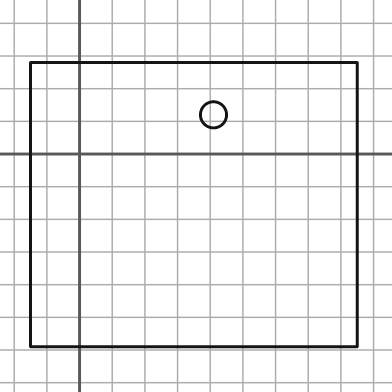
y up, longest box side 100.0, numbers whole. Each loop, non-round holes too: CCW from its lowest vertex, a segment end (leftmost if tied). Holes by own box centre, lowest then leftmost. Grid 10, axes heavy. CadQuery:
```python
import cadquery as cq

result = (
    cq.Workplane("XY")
    .moveTo(-15.0, -59.0)
    .lineTo(85.0, -59.0)
    .lineTo(85.0, 28.0)
    .lineTo(-15.0, 28.0)
    .close()
    .moveTo(41.0, 12.0)
    .circle(4.0)
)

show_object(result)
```